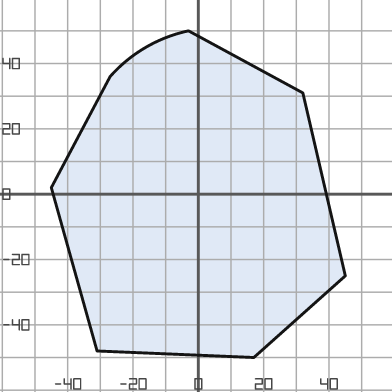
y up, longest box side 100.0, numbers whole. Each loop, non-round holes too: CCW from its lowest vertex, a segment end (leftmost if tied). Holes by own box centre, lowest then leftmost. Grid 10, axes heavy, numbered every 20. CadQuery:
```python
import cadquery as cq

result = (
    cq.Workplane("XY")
    .moveTo(17.0, -50.0)
    .lineTo(45.0, -25.0)
    .lineTo(32.0, 31.0)
    .lineTo(-3.0, 50.0)
    .threePointArc((-16.0, 45.0), (-27.0, 36.0))
    .lineTo(-45.0, 2.0)
    .lineTo(-31.0, -48.0)
    .close()
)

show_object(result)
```